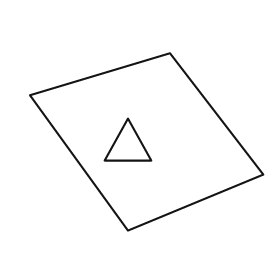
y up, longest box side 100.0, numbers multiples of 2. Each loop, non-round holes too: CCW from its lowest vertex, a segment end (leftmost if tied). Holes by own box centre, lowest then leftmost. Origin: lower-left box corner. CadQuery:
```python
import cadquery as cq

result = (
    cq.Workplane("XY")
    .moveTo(42.0, 0.0)
    .lineTo(100.0, 24.0)
    .lineTo(60.0, 76.0)
    .lineTo(0.0, 58.0)
    .close()
    .moveTo(32.0, 30.0)
    .lineTo(52.0, 30.0)
    .lineTo(42.0, 48.0)
    .close()
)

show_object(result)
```